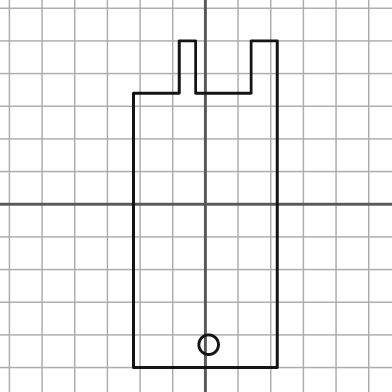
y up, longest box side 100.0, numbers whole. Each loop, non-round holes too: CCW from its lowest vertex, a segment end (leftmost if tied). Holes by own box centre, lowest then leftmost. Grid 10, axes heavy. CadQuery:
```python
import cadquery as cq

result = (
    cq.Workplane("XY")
    .moveTo(-22.0, -50.0)
    .lineTo(22.0, -50.0)
    .lineTo(22.0, 50.0)
    .lineTo(14.0, 50.0)
    .lineTo(14.0, 34.0)
    .lineTo(-3.0, 34.0)
    .lineTo(-3.0, 50.0)
    .lineTo(-8.0, 50.0)
    .lineTo(-8.0, 34.0)
    .lineTo(-22.0, 34.0)
    .close()
    .moveTo(1.0, -43.0)
    .circle(3.0)
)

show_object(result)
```